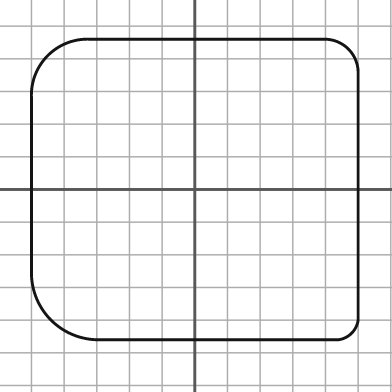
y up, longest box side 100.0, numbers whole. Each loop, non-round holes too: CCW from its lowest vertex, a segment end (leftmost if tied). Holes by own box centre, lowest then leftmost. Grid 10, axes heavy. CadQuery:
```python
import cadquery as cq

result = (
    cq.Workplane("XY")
    .moveTo(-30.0, -46.0)
    .lineTo(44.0, -46.0)
    .threePointArc((48.0, -44.0), (50.0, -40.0))
    .lineTo(50.0, 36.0)
    .threePointArc((47.0, 43.0), (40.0, 46.0))
    .lineTo(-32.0, 46.0)
    .threePointArc((-45.0, 41.0), (-50.0, 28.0))
    .lineTo(-50.0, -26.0)
    .threePointArc((-44.0, -40.0), (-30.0, -46.0))
    .close()
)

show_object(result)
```